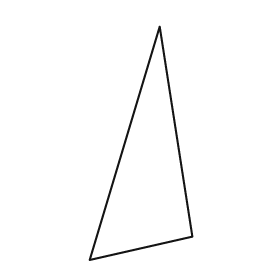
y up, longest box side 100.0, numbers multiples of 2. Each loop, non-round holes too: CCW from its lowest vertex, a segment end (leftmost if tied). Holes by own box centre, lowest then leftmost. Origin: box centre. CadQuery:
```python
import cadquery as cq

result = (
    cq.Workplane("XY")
    .moveTo(-22.0, -50.0)
    .lineTo(22.0, -40.0)
    .lineTo(8.0, 50.0)
    .close()
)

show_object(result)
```